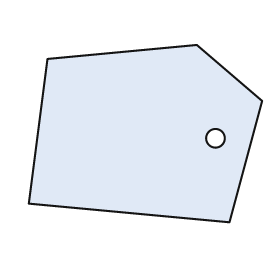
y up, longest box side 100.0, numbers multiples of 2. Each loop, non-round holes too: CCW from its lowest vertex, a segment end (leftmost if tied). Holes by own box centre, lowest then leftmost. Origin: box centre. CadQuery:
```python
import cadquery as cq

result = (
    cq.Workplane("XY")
    .moveTo(36.0, -38.0)
    .lineTo(50.0, 14.0)
    .lineTo(22.0, 38.0)
    .lineTo(-42.0, 32.0)
    .lineTo(-50.0, -30.0)
    .close()
    .moveTo(30.0, -2.0)
    .circle(4.0)
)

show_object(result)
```